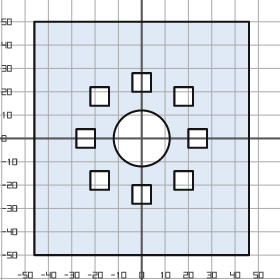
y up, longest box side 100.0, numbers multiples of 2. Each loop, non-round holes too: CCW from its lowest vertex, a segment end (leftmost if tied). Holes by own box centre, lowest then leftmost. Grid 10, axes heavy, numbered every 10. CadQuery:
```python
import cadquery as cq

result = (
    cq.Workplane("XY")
    .moveTo(-46.0, -50.0)
    .lineTo(46.0, -50.0)
    .lineTo(46.0, 50.0)
    .lineTo(-46.0, 50.0)
    .close()
    .moveTo(-4.0, -28.0)
    .lineTo(4.0, -28.0)
    .lineTo(4.0, -20.0)
    .lineTo(-4.0, -20.0)
    .close()
    .moveTo(-22.0, -22.0)
    .lineTo(-14.0, -22.0)
    .lineTo(-14.0, -14.0)
    .lineTo(-22.0, -14.0)
    .close()
    .moveTo(14.0, -22.0)
    .lineTo(22.0, -22.0)
    .lineTo(22.0, -14.0)
    .lineTo(14.0, -14.0)
    .close()
    .moveTo(-28.0, -4.0)
    .lineTo(-20.0, -4.0)
    .lineTo(-20.0, 4.0)
    .lineTo(-28.0, 4.0)
    .close()
    .moveTo(0.0, 0.0)
    .circle(12.0)
    .moveTo(20.0, -4.0)
    .lineTo(28.0, -4.0)
    .lineTo(28.0, 4.0)
    .lineTo(20.0, 4.0)
    .close()
    .moveTo(-22.0, 14.0)
    .lineTo(-14.0, 14.0)
    .lineTo(-14.0, 22.0)
    .lineTo(-22.0, 22.0)
    .close()
    .moveTo(14.0, 14.0)
    .lineTo(22.0, 14.0)
    .lineTo(22.0, 22.0)
    .lineTo(14.0, 22.0)
    .close()
    .moveTo(-4.0, 20.0)
    .lineTo(4.0, 20.0)
    .lineTo(4.0, 28.0)
    .lineTo(-4.0, 28.0)
    .close()
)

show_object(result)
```